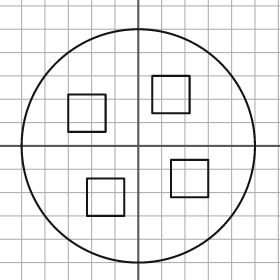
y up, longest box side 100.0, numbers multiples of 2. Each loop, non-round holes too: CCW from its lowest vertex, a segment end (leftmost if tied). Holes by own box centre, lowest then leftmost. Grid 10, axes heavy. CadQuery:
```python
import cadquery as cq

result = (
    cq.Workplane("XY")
    .moveTo(0.0, 0.0)
    .circle(50.0)
    .moveTo(-22.0, -30.0)
    .lineTo(-6.0, -30.0)
    .lineTo(-6.0, -14.0)
    .lineTo(-22.0, -14.0)
    .close()
    .moveTo(14.0, -22.0)
    .lineTo(30.0, -22.0)
    .lineTo(30.0, -6.0)
    .lineTo(14.0, -6.0)
    .close()
    .moveTo(-30.0, 6.0)
    .lineTo(-14.0, 6.0)
    .lineTo(-14.0, 22.0)
    .lineTo(-30.0, 22.0)
    .close()
    .moveTo(6.0, 14.0)
    .lineTo(22.0, 14.0)
    .lineTo(22.0, 30.0)
    .lineTo(6.0, 30.0)
    .close()
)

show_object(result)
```